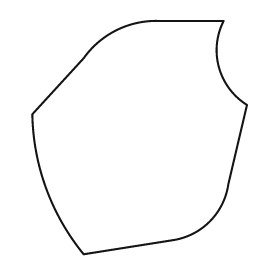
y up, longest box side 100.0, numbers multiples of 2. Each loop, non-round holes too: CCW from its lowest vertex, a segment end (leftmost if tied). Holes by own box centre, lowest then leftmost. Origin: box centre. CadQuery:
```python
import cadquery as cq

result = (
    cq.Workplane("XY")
    .moveTo(-24.0, -50.0)
    .lineTo(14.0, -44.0)
    .threePointArc((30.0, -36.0), (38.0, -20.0))
    .lineTo(46.0, 14.0)
    .threePointArc((34.0, 30.0), (36.0, 50.0))
    .lineTo(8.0, 50.0)
    .threePointArc((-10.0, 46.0), (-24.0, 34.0))
    .lineTo(-46.0, 10.0)
    .threePointArc((-40.0, -22.0), (-24.0, -50.0))
    .close()
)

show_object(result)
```